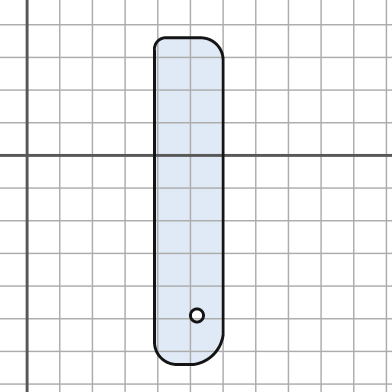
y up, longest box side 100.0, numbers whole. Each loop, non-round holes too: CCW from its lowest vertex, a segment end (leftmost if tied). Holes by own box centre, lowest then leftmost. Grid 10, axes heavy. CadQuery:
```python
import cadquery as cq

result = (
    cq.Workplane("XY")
    .moveTo(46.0, -64.0)
    .lineTo(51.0, -64.0)
    .threePointArc((57.0, -61.0), (60.0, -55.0))
    .lineTo(60.0, 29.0)
    .threePointArc((58.0, 34.0), (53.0, 36.0))
    .lineTo(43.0, 36.0)
    .threePointArc((40.0, 35.0), (39.0, 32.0))
    .lineTo(39.0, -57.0)
    .threePointArc((41.0, -62.0), (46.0, -64.0))
    .close()
    .moveTo(52.0, -49.0)
    .circle(2.0)
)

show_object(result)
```